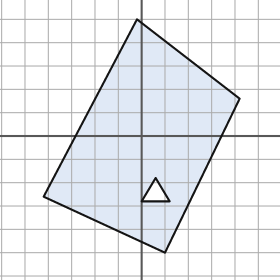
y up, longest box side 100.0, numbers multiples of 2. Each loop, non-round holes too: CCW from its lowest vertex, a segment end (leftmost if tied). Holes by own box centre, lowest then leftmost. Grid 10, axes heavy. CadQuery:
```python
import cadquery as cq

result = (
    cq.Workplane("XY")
    .moveTo(10.0, -50.0)
    .lineTo(42.0, 16.0)
    .lineTo(-2.0, 50.0)
    .lineTo(-42.0, -26.0)
    .close()
    .moveTo(0.0, -28.0)
    .lineTo(12.0, -28.0)
    .lineTo(6.0, -18.0)
    .close()
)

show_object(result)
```